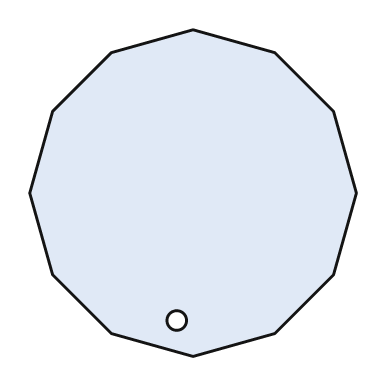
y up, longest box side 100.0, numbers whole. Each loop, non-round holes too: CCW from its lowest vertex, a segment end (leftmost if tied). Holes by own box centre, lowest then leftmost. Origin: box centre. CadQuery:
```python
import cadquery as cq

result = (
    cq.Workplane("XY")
    .moveTo(0.0, -50.0)
    .lineTo(25.0, -43.0)
    .lineTo(43.0, -25.0)
    .lineTo(50.0, 0.0)
    .lineTo(43.0, 25.0)
    .lineTo(25.0, 43.0)
    .lineTo(0.0, 50.0)
    .lineTo(-25.0, 43.0)
    .lineTo(-43.0, 25.0)
    .lineTo(-50.0, 0.0)
    .lineTo(-43.0, -25.0)
    .lineTo(-25.0, -43.0)
    .close()
    .moveTo(-5.0, -39.0)
    .circle(3.0)
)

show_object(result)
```